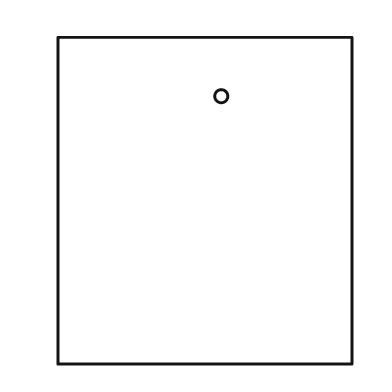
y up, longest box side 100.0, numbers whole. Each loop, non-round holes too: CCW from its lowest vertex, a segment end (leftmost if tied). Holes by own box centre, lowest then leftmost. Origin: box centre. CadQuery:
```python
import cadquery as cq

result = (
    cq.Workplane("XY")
    .moveTo(-45.0, -50.0)
    .lineTo(45.0, -50.0)
    .lineTo(45.0, 50.0)
    .lineTo(-45.0, 50.0)
    .close()
    .moveTo(5.0, 32.0)
    .circle(2.0)
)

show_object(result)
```